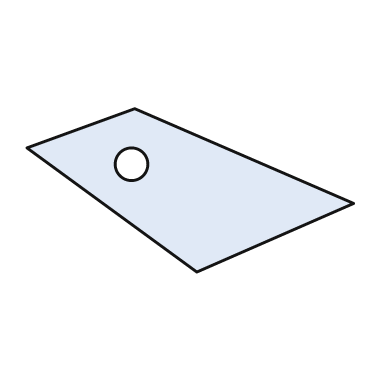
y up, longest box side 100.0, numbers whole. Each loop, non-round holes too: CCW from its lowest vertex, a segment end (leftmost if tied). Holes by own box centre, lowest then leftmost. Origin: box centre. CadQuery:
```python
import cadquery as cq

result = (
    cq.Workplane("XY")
    .moveTo(2.0, -25.0)
    .lineTo(50.0, -4.0)
    .lineTo(-17.0, 25.0)
    .lineTo(-50.0, 13.0)
    .close()
    .moveTo(-18.0, 8.0)
    .circle(5.0)
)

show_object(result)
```